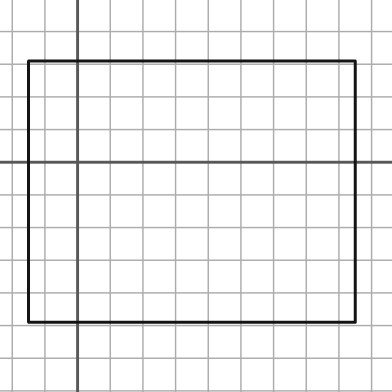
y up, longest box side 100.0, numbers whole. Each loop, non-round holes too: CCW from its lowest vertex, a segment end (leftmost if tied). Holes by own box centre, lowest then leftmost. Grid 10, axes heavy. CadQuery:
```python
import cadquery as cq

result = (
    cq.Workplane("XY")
    .moveTo(-15.0, -49.0)
    .lineTo(85.0, -49.0)
    .lineTo(85.0, 31.0)
    .lineTo(-15.0, 31.0)
    .close()
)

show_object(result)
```